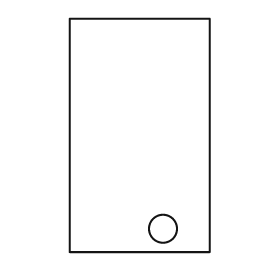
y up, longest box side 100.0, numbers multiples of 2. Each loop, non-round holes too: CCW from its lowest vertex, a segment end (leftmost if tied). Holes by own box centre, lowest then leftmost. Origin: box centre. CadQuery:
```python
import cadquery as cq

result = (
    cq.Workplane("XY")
    .moveTo(-30.0, -50.0)
    .lineTo(30.0, -50.0)
    .lineTo(30.0, 50.0)
    .lineTo(-30.0, 50.0)
    .close()
    .moveTo(10.0, -40.0)
    .circle(6.0)
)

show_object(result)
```